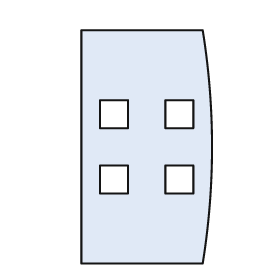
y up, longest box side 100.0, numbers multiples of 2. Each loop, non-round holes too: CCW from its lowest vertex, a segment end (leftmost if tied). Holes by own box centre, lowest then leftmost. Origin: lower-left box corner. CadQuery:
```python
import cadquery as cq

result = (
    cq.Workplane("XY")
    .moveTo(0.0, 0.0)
    .lineTo(52.0, 0.0)
    .threePointArc((56.0, 50.0), (52.0, 100.0))
    .lineTo(0.0, 100.0)
    .close()
    .moveTo(8.0, 30.0)
    .lineTo(20.0, 30.0)
    .lineTo(20.0, 42.0)
    .lineTo(8.0, 42.0)
    .close()
    .moveTo(36.0, 30.0)
    .lineTo(48.0, 30.0)
    .lineTo(48.0, 42.0)
    .lineTo(36.0, 42.0)
    .close()
    .moveTo(8.0, 58.0)
    .lineTo(20.0, 58.0)
    .lineTo(20.0, 70.0)
    .lineTo(8.0, 70.0)
    .close()
    .moveTo(36.0, 58.0)
    .lineTo(48.0, 58.0)
    .lineTo(48.0, 70.0)
    .lineTo(36.0, 70.0)
    .close()
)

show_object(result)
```